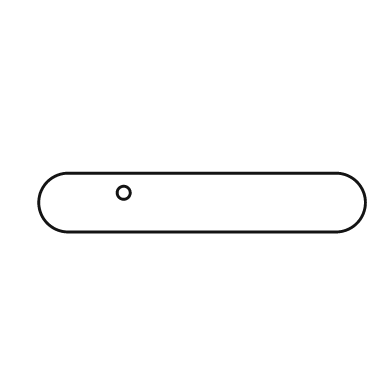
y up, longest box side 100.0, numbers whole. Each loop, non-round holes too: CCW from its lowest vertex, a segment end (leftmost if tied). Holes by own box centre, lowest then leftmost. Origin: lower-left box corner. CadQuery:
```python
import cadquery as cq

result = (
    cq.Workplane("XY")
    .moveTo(9.0, 0.0)
    .lineTo(91.0, 0.0)
    .threePointArc((100.0, 9.0), (91.0, 18.0))
    .lineTo(9.0, 18.0)
    .threePointArc((0.0, 9.0), (9.0, 0.0))
    .close()
    .moveTo(26.0, 12.0)
    .circle(2.0)
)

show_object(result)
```